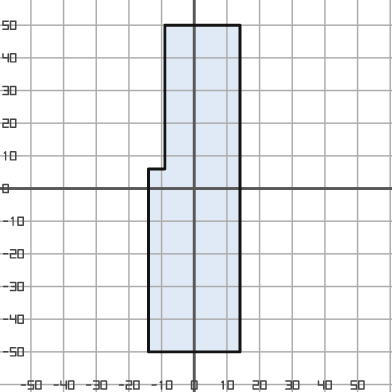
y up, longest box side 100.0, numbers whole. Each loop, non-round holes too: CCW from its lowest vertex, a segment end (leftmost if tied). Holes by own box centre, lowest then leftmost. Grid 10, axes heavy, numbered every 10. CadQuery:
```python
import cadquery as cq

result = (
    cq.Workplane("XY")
    .moveTo(-14.0, -50.0)
    .lineTo(14.0, -50.0)
    .lineTo(14.0, 50.0)
    .lineTo(-9.0, 50.0)
    .lineTo(-9.0, 6.0)
    .lineTo(-14.0, 6.0)
    .close()
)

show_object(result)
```